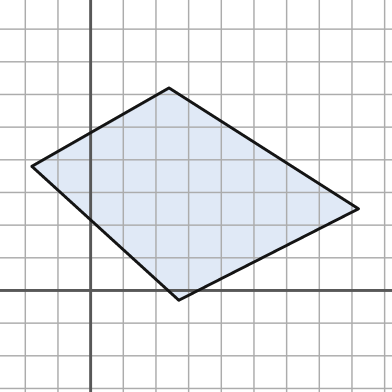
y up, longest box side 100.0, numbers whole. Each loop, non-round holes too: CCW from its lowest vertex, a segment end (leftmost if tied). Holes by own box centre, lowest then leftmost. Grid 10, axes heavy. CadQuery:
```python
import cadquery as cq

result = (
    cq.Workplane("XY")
    .moveTo(27.0, -3.0)
    .lineTo(82.0, 25.0)
    .lineTo(24.0, 62.0)
    .lineTo(-18.0, 38.0)
    .close()
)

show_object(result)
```